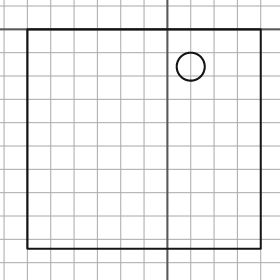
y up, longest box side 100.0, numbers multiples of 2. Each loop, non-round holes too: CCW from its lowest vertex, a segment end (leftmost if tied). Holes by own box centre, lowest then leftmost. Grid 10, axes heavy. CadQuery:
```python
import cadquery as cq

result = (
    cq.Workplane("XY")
    .moveTo(-60.0, -94.0)
    .lineTo(40.0, -94.0)
    .lineTo(40.0, 0.0)
    .lineTo(-60.0, 0.0)
    .close()
    .moveTo(10.0, -16.0)
    .circle(6.0)
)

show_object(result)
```